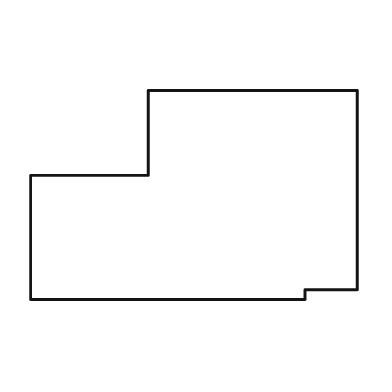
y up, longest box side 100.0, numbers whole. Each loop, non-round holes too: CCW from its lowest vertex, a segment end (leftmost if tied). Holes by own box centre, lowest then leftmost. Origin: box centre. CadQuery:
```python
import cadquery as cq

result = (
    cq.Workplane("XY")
    .moveTo(-50.0, -32.0)
    .lineTo(34.0, -32.0)
    .lineTo(34.0, -29.0)
    .lineTo(50.0, -29.0)
    .lineTo(50.0, 32.0)
    .lineTo(-14.0, 32.0)
    .lineTo(-14.0, 6.0)
    .lineTo(-50.0, 6.0)
    .close()
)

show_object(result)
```